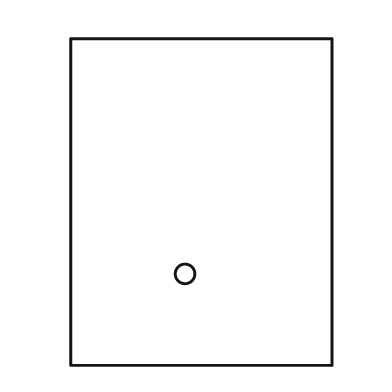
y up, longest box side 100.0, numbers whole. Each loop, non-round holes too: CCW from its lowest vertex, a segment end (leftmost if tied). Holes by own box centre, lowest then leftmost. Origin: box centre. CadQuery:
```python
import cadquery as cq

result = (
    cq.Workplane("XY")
    .moveTo(-40.0, -50.0)
    .lineTo(40.0, -50.0)
    .lineTo(40.0, 50.0)
    .lineTo(-40.0, 50.0)
    .close()
    .moveTo(-5.0, -22.0)
    .circle(3.0)
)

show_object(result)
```